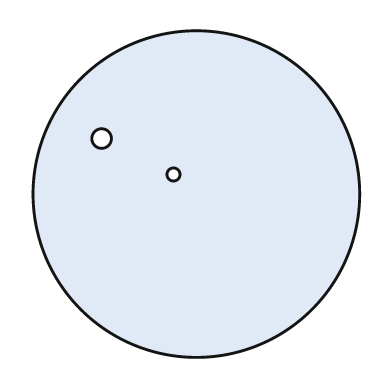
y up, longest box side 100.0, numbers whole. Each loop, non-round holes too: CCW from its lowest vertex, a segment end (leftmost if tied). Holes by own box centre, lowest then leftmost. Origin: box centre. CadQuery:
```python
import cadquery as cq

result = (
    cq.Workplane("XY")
    .moveTo(0.0, 0.0)
    .circle(50.0)
    .moveTo(-7.0, 6.0)
    .circle(2.0)
    .moveTo(-29.0, 17.0)
    .circle(3.0)
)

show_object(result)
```